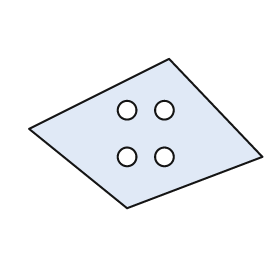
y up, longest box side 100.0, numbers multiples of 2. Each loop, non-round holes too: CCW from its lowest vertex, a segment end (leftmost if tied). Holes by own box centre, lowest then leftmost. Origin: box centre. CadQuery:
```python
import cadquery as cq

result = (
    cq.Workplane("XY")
    .moveTo(-8.0, -32.0)
    .lineTo(50.0, -10.0)
    .lineTo(10.0, 32.0)
    .lineTo(-50.0, 2.0)
    .close()
    .moveTo(-8.0, -10.0)
    .circle(4.0)
    .moveTo(8.0, -10.0)
    .circle(4.0)
    .moveTo(-8.0, 10.0)
    .circle(4.0)
    .moveTo(8.0, 10.0)
    .circle(4.0)
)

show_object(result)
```